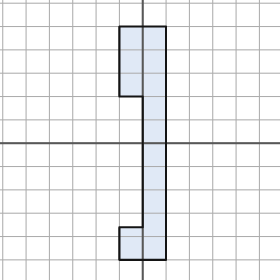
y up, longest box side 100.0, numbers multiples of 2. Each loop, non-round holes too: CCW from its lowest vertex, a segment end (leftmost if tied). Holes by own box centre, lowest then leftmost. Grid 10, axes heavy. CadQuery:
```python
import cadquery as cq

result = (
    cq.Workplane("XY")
    .moveTo(-10.0, -50.0)
    .lineTo(10.0, -50.0)
    .lineTo(10.0, 50.0)
    .lineTo(-10.0, 50.0)
    .lineTo(-10.0, 20.0)
    .lineTo(0.0, 20.0)
    .lineTo(0.0, -36.0)
    .lineTo(-10.0, -36.0)
    .close()
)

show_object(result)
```